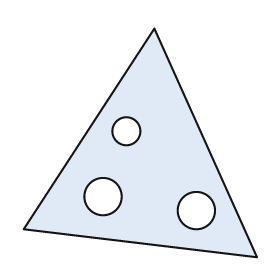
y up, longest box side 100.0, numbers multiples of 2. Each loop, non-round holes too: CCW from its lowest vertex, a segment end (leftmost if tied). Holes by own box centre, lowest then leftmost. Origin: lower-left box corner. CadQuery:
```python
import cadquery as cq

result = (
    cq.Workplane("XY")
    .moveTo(100.0, 0.0)
    .lineTo(56.0, 98.0)
    .lineTo(0.0, 12.0)
    .close()
    .moveTo(74.0, 20.0)
    .circle(8.0)
    .moveTo(34.0, 26.0)
    .circle(8.0)
    .moveTo(44.0, 54.0)
    .circle(6.0)
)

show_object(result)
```